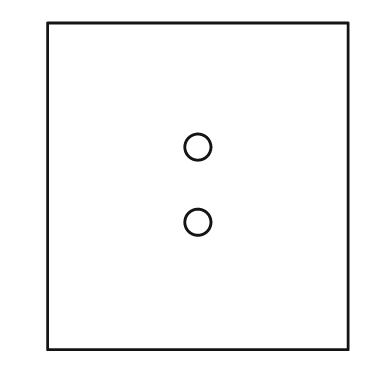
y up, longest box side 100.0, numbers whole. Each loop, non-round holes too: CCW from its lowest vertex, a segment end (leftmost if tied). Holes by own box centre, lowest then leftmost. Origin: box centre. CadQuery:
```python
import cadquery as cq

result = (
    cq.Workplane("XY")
    .moveTo(-46.0, -50.0)
    .lineTo(46.0, -50.0)
    .lineTo(46.0, 50.0)
    .lineTo(-46.0, 50.0)
    .close()
    .moveTo(0.0, -11.0)
    .circle(4.0)
    .moveTo(0.0, 12.0)
    .circle(4.0)
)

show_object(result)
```